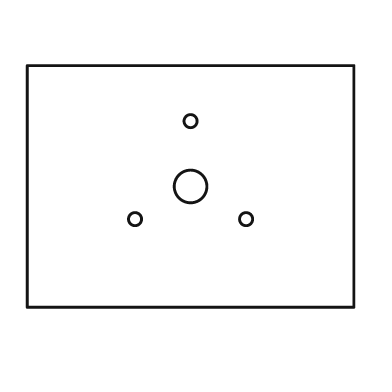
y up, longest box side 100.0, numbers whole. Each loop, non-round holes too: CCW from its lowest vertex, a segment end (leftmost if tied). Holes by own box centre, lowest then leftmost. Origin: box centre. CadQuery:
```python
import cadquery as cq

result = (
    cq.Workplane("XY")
    .moveTo(-50.0, -37.0)
    .lineTo(50.0, -37.0)
    .lineTo(50.0, 37.0)
    .lineTo(-50.0, 37.0)
    .close()
    .moveTo(-17.0, -10.0)
    .circle(2.0)
    .moveTo(17.0, -10.0)
    .circle(2.0)
    .moveTo(0.0, 0.0)
    .circle(5.0)
    .moveTo(0.0, 20.0)
    .circle(2.0)
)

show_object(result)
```